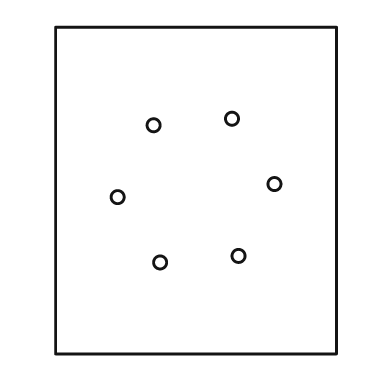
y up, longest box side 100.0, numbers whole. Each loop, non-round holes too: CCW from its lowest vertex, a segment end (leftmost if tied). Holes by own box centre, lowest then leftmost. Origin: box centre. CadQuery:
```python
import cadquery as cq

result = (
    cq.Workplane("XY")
    .moveTo(-43.0, -50.0)
    .lineTo(43.0, -50.0)
    .lineTo(43.0, 50.0)
    .lineTo(-43.0, 50.0)
    .close()
    .moveTo(-11.0, -22.0)
    .circle(2.0)
    .moveTo(13.0, -20.0)
    .circle(2.0)
    .moveTo(-24.0, -2.0)
    .circle(2.0)
    .moveTo(24.0, 2.0)
    .circle(2.0)
    .moveTo(-13.0, 20.0)
    .circle(2.0)
    .moveTo(11.0, 22.0)
    .circle(2.0)
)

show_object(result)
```